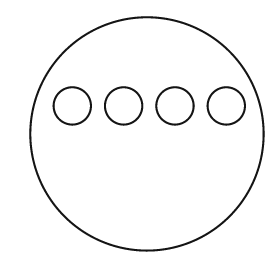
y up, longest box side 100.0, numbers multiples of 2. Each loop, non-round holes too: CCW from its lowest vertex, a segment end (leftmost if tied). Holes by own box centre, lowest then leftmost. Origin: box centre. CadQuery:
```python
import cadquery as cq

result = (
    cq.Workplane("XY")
    .moveTo(0.0, 0.0)
    .circle(50.0)
    .moveTo(-32.0, 12.0)
    .circle(8.0)
    .moveTo(-10.0, 12.0)
    .circle(8.0)
    .moveTo(12.0, 12.0)
    .circle(8.0)
    .moveTo(34.0, 12.0)
    .circle(8.0)
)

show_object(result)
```